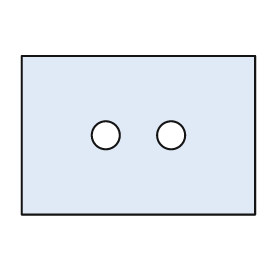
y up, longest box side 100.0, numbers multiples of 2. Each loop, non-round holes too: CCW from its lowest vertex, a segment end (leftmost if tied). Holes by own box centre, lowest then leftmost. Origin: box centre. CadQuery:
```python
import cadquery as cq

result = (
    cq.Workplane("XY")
    .moveTo(-50.0, -34.0)
    .lineTo(50.0, -34.0)
    .lineTo(50.0, 34.0)
    .lineTo(-50.0, 34.0)
    .close()
    .moveTo(-14.0, 0.0)
    .circle(6.0)
    .moveTo(14.0, 0.0)
    .circle(6.0)
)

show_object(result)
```